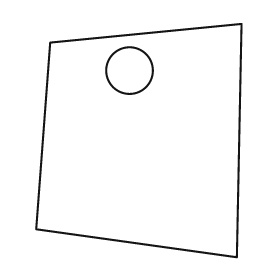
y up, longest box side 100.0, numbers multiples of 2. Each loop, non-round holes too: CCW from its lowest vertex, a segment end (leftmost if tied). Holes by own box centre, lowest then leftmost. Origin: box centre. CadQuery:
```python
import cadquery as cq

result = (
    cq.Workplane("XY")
    .moveTo(42.0, -50.0)
    .lineTo(44.0, 50.0)
    .lineTo(-38.0, 42.0)
    .lineTo(-44.0, -38.0)
    .close()
    .moveTo(-4.0, 30.0)
    .circle(10.0)
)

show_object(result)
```